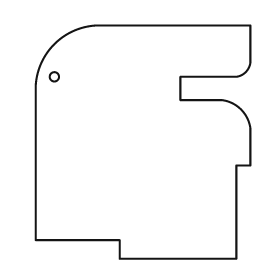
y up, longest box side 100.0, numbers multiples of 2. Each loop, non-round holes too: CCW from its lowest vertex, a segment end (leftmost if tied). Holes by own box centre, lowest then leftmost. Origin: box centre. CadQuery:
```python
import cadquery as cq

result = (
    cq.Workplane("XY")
    .moveTo(-10.0, -50.0)
    .lineTo(40.0, -50.0)
    .lineTo(40.0, -10.0)
    .lineTo(46.0, -10.0)
    .lineTo(46.0, 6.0)
    .threePointArc((42.0, 14.0), (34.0, 18.0))
    .lineTo(16.0, 18.0)
    .lineTo(16.0, 28.0)
    .lineTo(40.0, 28.0)
    .threePointArc((44.0, 30.0), (46.0, 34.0))
    .lineTo(46.0, 50.0)
    .lineTo(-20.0, 50.0)
    .threePointArc((-38.0, 42.0), (-46.0, 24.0))
    .lineTo(-46.0, -42.0)
    .lineTo(-10.0, -42.0)
    .close()
    .moveTo(-38.0, 28.0)
    .circle(2.0)
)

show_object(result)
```